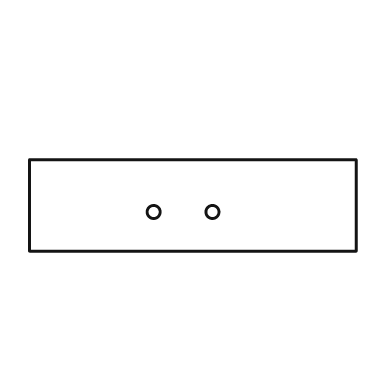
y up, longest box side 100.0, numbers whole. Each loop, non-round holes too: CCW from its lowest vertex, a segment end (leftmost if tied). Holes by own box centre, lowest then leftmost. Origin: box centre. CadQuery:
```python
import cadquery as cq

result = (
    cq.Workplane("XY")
    .moveTo(-50.0, -14.0)
    .lineTo(50.0, -14.0)
    .lineTo(50.0, 14.0)
    .lineTo(-50.0, 14.0)
    .close()
    .moveTo(-12.0, -2.0)
    .circle(2.0)
    .moveTo(6.0, -2.0)
    .circle(2.0)
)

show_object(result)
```